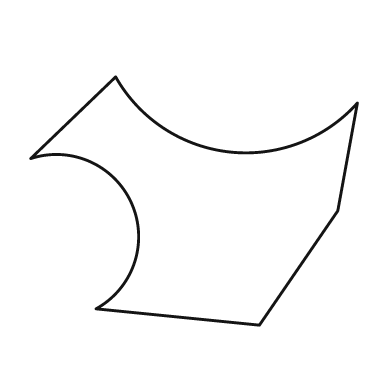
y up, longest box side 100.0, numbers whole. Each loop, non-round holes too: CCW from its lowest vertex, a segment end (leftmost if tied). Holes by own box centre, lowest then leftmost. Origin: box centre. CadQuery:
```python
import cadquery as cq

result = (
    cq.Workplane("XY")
    .moveTo(20.0, -38.0)
    .lineTo(44.0, -3.0)
    .lineTo(50.0, 30.0)
    .threePointArc((11.0, 15.0), (-24.0, 38.0))
    .lineTo(-50.0, 13.0)
    .threePointArc((-19.0, -1.0), (-30.0, -33.0))
    .close()
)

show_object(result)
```